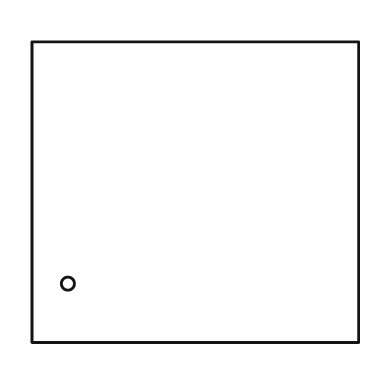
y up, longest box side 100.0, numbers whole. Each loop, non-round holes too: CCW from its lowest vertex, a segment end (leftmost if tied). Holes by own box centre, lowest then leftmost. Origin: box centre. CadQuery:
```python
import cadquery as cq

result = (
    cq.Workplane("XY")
    .moveTo(-50.0, -46.0)
    .lineTo(50.0, -46.0)
    .lineTo(50.0, 46.0)
    .lineTo(-50.0, 46.0)
    .close()
    .moveTo(-39.0, -28.0)
    .circle(2.0)
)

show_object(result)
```